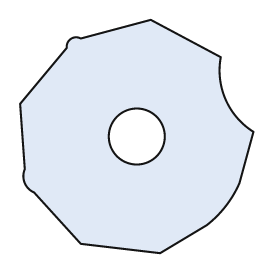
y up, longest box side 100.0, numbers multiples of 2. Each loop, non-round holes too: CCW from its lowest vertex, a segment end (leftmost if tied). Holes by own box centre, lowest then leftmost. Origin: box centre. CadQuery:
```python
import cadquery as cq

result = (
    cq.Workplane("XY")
    .moveTo(10.0, -50.0)
    .lineTo(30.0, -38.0)
    .threePointArc((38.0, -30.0), (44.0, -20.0))
    .lineTo(50.0, 2.0)
    .threePointArc((38.0, 16.0), (36.0, 34.0))
    .lineTo(6.0, 50.0)
    .lineTo(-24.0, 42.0)
    .threePointArc((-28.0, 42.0), (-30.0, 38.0))
    .lineTo(-50.0, 14.0)
    .lineTo(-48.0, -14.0)
    .threePointArc((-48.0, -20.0), (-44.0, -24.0))
    .lineTo(-24.0, -46.0)
    .close()
    .moveTo(0.0, 0.0)
    .circle(12.0)
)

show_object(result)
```